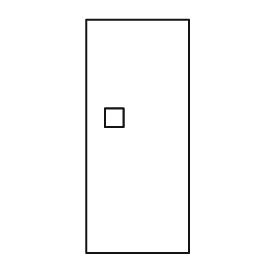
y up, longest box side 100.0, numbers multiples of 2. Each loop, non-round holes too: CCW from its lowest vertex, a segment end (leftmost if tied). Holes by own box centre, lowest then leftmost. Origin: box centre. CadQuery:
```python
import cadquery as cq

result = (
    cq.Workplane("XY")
    .moveTo(-22.0, -50.0)
    .lineTo(22.0, -50.0)
    .lineTo(22.0, 50.0)
    .lineTo(-22.0, 50.0)
    .close()
    .moveTo(-14.0, 4.0)
    .lineTo(-6.0, 4.0)
    .lineTo(-6.0, 12.0)
    .lineTo(-14.0, 12.0)
    .close()
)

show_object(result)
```